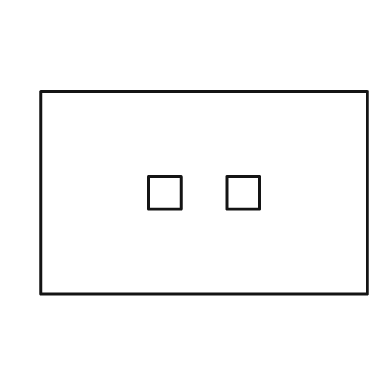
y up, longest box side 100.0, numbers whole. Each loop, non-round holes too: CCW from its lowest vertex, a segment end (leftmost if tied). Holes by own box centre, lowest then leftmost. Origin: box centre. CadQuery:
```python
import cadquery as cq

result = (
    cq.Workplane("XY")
    .moveTo(-50.0, -31.0)
    .lineTo(50.0, -31.0)
    .lineTo(50.0, 31.0)
    .lineTo(-50.0, 31.0)
    .close()
    .moveTo(-17.0, -5.0)
    .lineTo(-7.0, -5.0)
    .lineTo(-7.0, 5.0)
    .lineTo(-17.0, 5.0)
    .close()
    .moveTo(7.0, -5.0)
    .lineTo(17.0, -5.0)
    .lineTo(17.0, 5.0)
    .lineTo(7.0, 5.0)
    .close()
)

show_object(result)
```